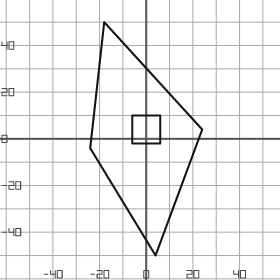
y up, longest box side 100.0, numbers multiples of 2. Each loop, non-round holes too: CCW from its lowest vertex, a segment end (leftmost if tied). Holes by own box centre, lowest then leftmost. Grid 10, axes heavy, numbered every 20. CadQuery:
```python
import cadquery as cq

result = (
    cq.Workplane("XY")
    .moveTo(4.0, -50.0)
    .lineTo(24.0, 4.0)
    .lineTo(-18.0, 50.0)
    .lineTo(-24.0, -4.0)
    .close()
    .moveTo(-6.0, -2.0)
    .lineTo(6.0, -2.0)
    .lineTo(6.0, 10.0)
    .lineTo(-6.0, 10.0)
    .close()
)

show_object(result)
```